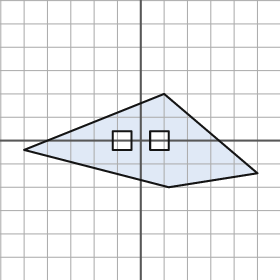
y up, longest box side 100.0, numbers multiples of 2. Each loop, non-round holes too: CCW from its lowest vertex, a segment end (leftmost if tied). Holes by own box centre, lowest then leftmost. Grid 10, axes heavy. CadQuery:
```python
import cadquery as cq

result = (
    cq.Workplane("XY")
    .moveTo(12.0, -20.0)
    .lineTo(50.0, -14.0)
    .lineTo(10.0, 20.0)
    .lineTo(-50.0, -4.0)
    .close()
    .moveTo(-12.0, -4.0)
    .lineTo(-4.0, -4.0)
    .lineTo(-4.0, 4.0)
    .lineTo(-12.0, 4.0)
    .close()
    .moveTo(4.0, -4.0)
    .lineTo(12.0, -4.0)
    .lineTo(12.0, 4.0)
    .lineTo(4.0, 4.0)
    .close()
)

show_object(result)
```